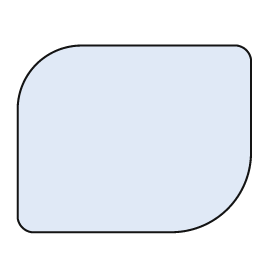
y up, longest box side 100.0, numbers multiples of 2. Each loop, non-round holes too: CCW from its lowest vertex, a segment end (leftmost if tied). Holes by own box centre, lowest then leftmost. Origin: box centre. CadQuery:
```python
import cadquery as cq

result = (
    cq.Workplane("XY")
    .moveTo(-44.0, -40.0)
    .lineTo(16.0, -40.0)
    .threePointArc((40.0, -30.0), (50.0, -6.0))
    .lineTo(50.0, 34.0)
    .threePointArc((48.0, 38.0), (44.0, 40.0))
    .lineTo(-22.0, 40.0)
    .threePointArc((-42.0, 32.0), (-50.0, 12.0))
    .lineTo(-50.0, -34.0)
    .threePointArc((-48.0, -38.0), (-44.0, -40.0))
    .close()
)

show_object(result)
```